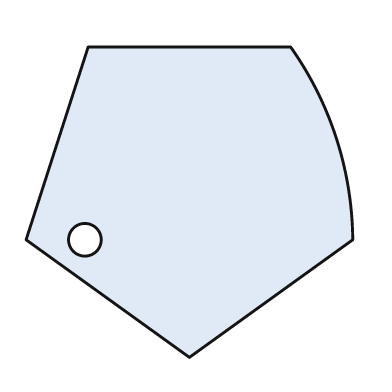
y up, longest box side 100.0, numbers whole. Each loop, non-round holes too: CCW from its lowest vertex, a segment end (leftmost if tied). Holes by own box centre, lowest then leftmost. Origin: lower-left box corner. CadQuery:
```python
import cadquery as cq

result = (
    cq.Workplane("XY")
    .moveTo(50.0, 0.0)
    .lineTo(100.0, 36.0)
    .threePointArc((95.0, 67.0), (81.0, 95.0))
    .lineTo(19.0, 95.0)
    .lineTo(0.0, 36.0)
    .close()
    .moveTo(18.0, 36.0)
    .circle(5.0)
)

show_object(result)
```